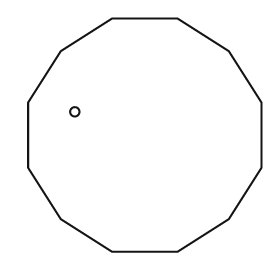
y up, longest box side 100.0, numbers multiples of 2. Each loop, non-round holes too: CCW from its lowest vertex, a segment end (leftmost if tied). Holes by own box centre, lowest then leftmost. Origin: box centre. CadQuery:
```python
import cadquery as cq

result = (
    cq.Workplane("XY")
    .moveTo(-14.0, -50.0)
    .lineTo(14.0, -50.0)
    .lineTo(36.0, -36.0)
    .lineTo(50.0, -14.0)
    .lineTo(50.0, 14.0)
    .lineTo(36.0, 36.0)
    .lineTo(14.0, 50.0)
    .lineTo(-14.0, 50.0)
    .lineTo(-36.0, 36.0)
    .lineTo(-50.0, 14.0)
    .lineTo(-50.0, -14.0)
    .lineTo(-36.0, -36.0)
    .close()
    .moveTo(-30.0, 10.0)
    .circle(2.0)
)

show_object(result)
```